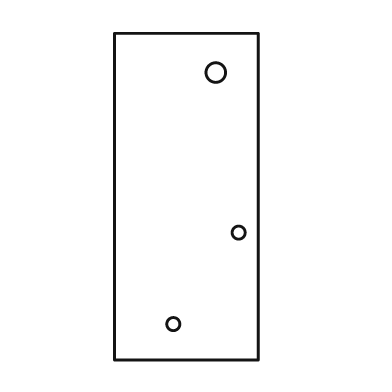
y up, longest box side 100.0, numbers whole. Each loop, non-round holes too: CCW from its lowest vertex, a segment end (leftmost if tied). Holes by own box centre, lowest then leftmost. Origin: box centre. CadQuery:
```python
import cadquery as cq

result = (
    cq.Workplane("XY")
    .moveTo(-22.0, -50.0)
    .lineTo(22.0, -50.0)
    .lineTo(22.0, 50.0)
    .lineTo(-22.0, 50.0)
    .close()
    .moveTo(-4.0, -39.0)
    .circle(2.0)
    .moveTo(16.0, -11.0)
    .circle(2.0)
    .moveTo(9.0, 38.0)
    .circle(3.0)
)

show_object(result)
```